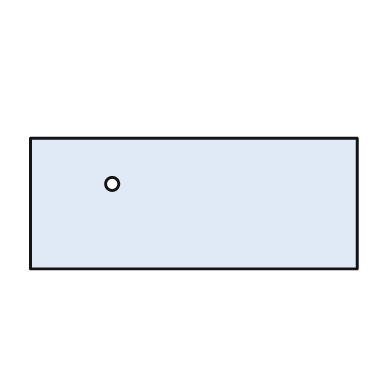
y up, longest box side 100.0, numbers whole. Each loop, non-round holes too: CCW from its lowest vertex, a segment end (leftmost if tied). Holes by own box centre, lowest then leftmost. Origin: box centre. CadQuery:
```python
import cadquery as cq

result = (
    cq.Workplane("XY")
    .moveTo(-50.0, -20.0)
    .lineTo(50.0, -20.0)
    .lineTo(50.0, 20.0)
    .lineTo(-50.0, 20.0)
    .close()
    .moveTo(-25.0, 6.0)
    .circle(2.0)
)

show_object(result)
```